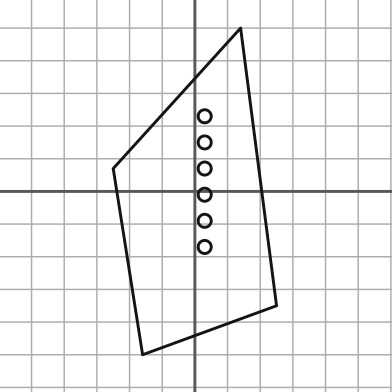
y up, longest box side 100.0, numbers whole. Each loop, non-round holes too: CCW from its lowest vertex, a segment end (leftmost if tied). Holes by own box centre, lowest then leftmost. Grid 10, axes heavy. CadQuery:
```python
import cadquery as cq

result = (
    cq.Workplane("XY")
    .moveTo(-16.0, -50.0)
    .lineTo(25.0, -35.0)
    .lineTo(14.0, 50.0)
    .lineTo(-25.0, 7.0)
    .close()
    .moveTo(3.0, -17.0)
    .circle(2.0)
    .moveTo(3.0, -9.0)
    .circle(2.0)
    .moveTo(3.0, -1.0)
    .circle(2.0)
    .moveTo(3.0, 7.0)
    .circle(2.0)
    .moveTo(3.0, 15.0)
    .circle(2.0)
    .moveTo(3.0, 23.0)
    .circle(2.0)
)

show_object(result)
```